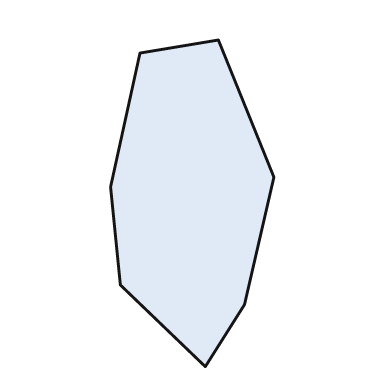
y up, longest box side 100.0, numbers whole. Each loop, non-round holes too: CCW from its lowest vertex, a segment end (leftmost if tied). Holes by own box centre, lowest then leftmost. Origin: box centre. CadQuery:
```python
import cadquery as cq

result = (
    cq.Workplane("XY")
    .moveTo(4.0, -50.0)
    .lineTo(16.0, -31.0)
    .lineTo(25.0, 8.0)
    .lineTo(8.0, 50.0)
    .lineTo(-16.0, 46.0)
    .lineTo(-25.0, 5.0)
    .lineTo(-22.0, -25.0)
    .close()
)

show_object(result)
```